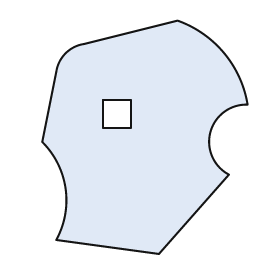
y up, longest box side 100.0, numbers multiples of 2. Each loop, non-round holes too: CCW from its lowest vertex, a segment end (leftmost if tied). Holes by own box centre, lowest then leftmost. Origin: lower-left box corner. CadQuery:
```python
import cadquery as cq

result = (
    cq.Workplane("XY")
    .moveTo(50.0, 0.0)
    .lineTo(80.0, 34.0)
    .threePointArc((72.0, 52.0), (88.0, 64.0))
    .threePointArc((78.0, 86.0), (58.0, 100.0))
    .lineTo(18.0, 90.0)
    .threePointArc((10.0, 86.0), (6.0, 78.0))
    .lineTo(0.0, 48.0)
    .threePointArc((10.0, 28.0), (6.0, 6.0))
    .close()
    .moveTo(26.0, 54.0)
    .lineTo(38.0, 54.0)
    .lineTo(38.0, 66.0)
    .lineTo(26.0, 66.0)
    .close()
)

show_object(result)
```